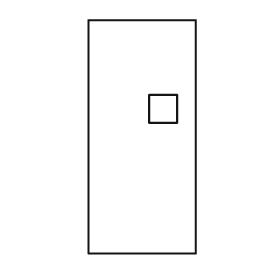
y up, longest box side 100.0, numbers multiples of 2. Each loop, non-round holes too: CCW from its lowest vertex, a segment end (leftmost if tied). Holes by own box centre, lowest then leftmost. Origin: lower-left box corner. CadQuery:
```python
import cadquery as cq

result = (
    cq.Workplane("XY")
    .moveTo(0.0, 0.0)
    .lineTo(46.0, 0.0)
    .lineTo(46.0, 100.0)
    .lineTo(0.0, 100.0)
    .close()
    .moveTo(26.0, 56.0)
    .lineTo(38.0, 56.0)
    .lineTo(38.0, 68.0)
    .lineTo(26.0, 68.0)
    .close()
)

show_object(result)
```